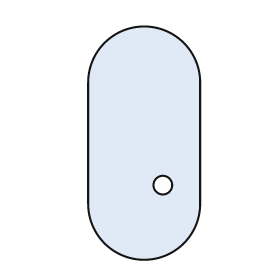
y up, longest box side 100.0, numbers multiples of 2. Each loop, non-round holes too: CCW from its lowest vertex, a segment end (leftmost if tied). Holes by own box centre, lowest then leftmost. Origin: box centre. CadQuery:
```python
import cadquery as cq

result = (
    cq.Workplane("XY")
    .moveTo(-24.0, -26.0)
    .threePointArc((0.0, -50.0), (24.0, -26.0))
    .lineTo(24.0, 26.0)
    .threePointArc((0.0, 50.0), (-24.0, 26.0))
    .close()
    .moveTo(8.0, -18.0)
    .circle(4.0)
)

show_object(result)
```